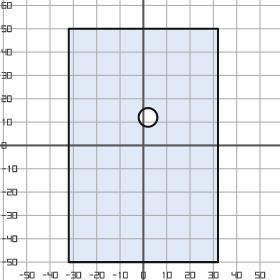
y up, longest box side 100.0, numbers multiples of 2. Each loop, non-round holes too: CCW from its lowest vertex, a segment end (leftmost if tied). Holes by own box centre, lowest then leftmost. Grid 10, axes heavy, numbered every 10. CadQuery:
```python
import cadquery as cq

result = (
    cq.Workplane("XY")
    .moveTo(-32.0, -50.0)
    .lineTo(32.0, -50.0)
    .lineTo(32.0, 50.0)
    .lineTo(-32.0, 50.0)
    .close()
    .moveTo(2.0, 12.0)
    .circle(4.0)
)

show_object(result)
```